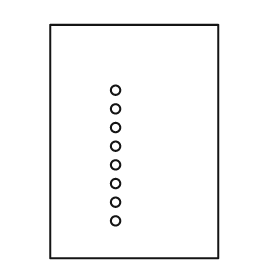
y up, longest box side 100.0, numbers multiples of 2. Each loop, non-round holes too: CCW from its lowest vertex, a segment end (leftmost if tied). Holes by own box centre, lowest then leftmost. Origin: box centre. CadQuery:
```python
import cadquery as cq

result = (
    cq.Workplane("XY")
    .moveTo(-36.0, -50.0)
    .lineTo(36.0, -50.0)
    .lineTo(36.0, 50.0)
    .lineTo(-36.0, 50.0)
    .close()
    .moveTo(-8.0, -34.0)
    .circle(2.0)
    .moveTo(-8.0, -26.0)
    .circle(2.0)
    .moveTo(-8.0, -18.0)
    .circle(2.0)
    .moveTo(-8.0, -10.0)
    .circle(2.0)
    .moveTo(-8.0, -2.0)
    .circle(2.0)
    .moveTo(-8.0, 6.0)
    .circle(2.0)
    .moveTo(-8.0, 14.0)
    .circle(2.0)
    .moveTo(-8.0, 22.0)
    .circle(2.0)
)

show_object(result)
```